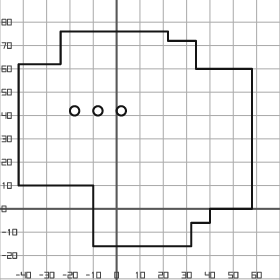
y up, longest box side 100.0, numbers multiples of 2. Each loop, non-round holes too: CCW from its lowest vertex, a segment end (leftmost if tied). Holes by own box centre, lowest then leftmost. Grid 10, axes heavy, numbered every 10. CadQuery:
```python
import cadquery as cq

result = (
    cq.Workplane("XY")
    .moveTo(-10.0, -16.0)
    .lineTo(32.0, -16.0)
    .lineTo(32.0, -6.0)
    .lineTo(40.0, -6.0)
    .lineTo(40.0, 0.0)
    .lineTo(58.0, 0.0)
    .lineTo(58.0, 60.0)
    .lineTo(34.0, 60.0)
    .lineTo(34.0, 72.0)
    .lineTo(22.0, 72.0)
    .lineTo(22.0, 76.0)
    .lineTo(-24.0, 76.0)
    .lineTo(-24.0, 62.0)
    .lineTo(-42.0, 62.0)
    .lineTo(-42.0, 10.0)
    .lineTo(-10.0, 10.0)
    .close()
    .moveTo(-18.0, 42.0)
    .circle(2.0)
    .moveTo(-8.0, 42.0)
    .circle(2.0)
    .moveTo(2.0, 42.0)
    .circle(2.0)
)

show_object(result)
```